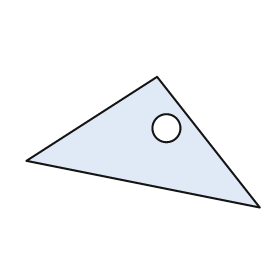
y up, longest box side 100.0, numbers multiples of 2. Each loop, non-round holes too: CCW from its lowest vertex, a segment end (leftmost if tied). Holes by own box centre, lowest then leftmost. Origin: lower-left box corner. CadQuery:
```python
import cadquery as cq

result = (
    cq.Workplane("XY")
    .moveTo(100.0, 0.0)
    .lineTo(56.0, 56.0)
    .lineTo(0.0, 20.0)
    .close()
    .moveTo(60.0, 34.0)
    .circle(6.0)
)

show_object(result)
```